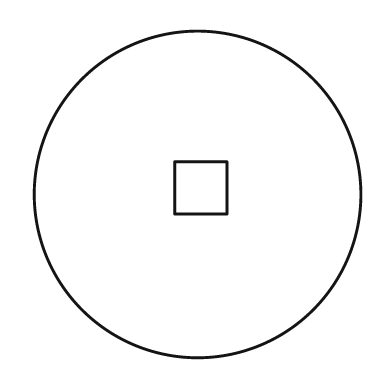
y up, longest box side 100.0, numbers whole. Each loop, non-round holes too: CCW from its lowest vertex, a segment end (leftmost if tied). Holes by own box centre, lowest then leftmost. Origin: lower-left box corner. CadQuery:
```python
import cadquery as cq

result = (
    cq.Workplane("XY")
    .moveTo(50.0, 50.0)
    .circle(50.0)
    .moveTo(43.0, 44.0)
    .lineTo(59.0, 44.0)
    .lineTo(59.0, 60.0)
    .lineTo(43.0, 60.0)
    .close()
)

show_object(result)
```